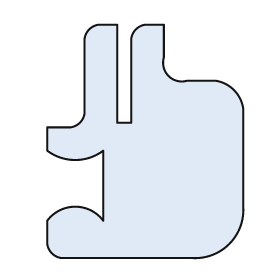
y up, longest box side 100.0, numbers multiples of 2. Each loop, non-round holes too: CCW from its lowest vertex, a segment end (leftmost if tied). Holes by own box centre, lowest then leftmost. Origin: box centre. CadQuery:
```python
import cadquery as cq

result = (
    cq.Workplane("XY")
    .moveTo(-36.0, -50.0)
    .lineTo(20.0, -50.0)
    .threePointArc((36.0, -44.0), (42.0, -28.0))
    .lineTo(42.0, 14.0)
    .threePointArc((38.0, 22.0), (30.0, 26.0))
    .lineTo(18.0, 26.0)
    .threePointArc((10.0, 28.0), (8.0, 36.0))
    .lineTo(8.0, 50.0)
    .lineTo(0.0, 50.0)
    .threePointArc((-4.0, 48.0), (-6.0, 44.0))
    .lineTo(-6.0, 8.0)
    .lineTo(-12.0, 8.0)
    .lineTo(-12.0, 50.0)
    .lineTo(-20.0, 50.0)
    .threePointArc((-24.0, 48.0), (-26.0, 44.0))
    .lineTo(-26.0, 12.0)
    .threePointArc((-28.0, 8.0), (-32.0, 6.0))
    .lineTo(-42.0, 6.0)
    .lineTo(-42.0, -4.0)
    .threePointArc((-30.0, -8.0), (-18.0, -4.0))
    .lineTo(-18.0, -34.0)
    .threePointArc((-30.0, -28.0), (-42.0, -34.0))
    .lineTo(-42.0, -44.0)
    .threePointArc((-40.0, -48.0), (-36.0, -50.0))
    .close()
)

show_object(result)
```